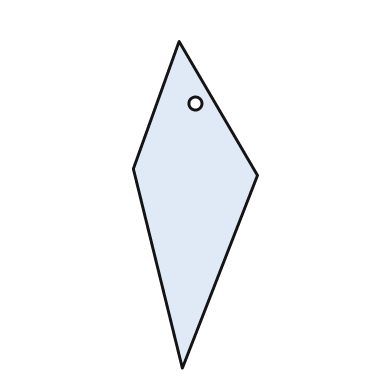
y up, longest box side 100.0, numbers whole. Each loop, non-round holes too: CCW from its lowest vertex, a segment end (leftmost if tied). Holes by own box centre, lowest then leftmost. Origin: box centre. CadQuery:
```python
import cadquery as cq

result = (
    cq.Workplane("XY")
    .moveTo(-4.0, -50.0)
    .lineTo(19.0, 9.0)
    .lineTo(-5.0, 50.0)
    .lineTo(-19.0, 11.0)
    .close()
    .moveTo(0.0, 31.0)
    .circle(2.0)
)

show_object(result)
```